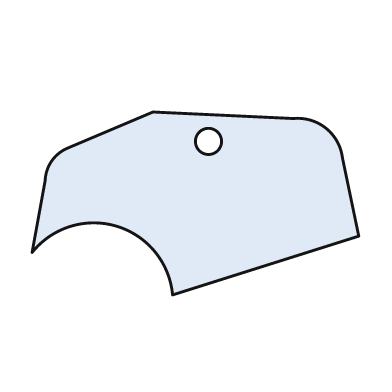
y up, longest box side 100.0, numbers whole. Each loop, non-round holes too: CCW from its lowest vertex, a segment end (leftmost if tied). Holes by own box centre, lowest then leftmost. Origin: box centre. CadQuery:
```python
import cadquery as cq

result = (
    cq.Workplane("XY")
    .moveTo(-7.0, -28.0)
    .lineTo(50.0, -10.0)
    .lineTo(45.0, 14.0)
    .threePointArc((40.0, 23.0), (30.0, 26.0))
    .lineTo(-13.0, 28.0)
    .lineTo(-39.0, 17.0)
    .threePointArc((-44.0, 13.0), (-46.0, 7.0))
    .lineTo(-50.0, -15.0)
    .threePointArc((-24.0, -7.0), (-7.0, -28.0))
    .close()
    .moveTo(4.0, 19.0)
    .circle(4.0)
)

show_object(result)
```